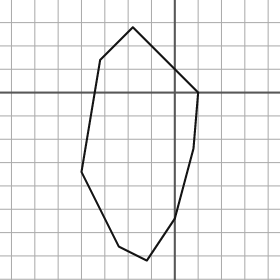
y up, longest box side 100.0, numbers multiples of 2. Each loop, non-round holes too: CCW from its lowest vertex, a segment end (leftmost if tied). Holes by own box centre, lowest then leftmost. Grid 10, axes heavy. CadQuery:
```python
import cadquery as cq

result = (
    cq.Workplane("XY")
    .moveTo(-12.0, -72.0)
    .lineTo(0.0, -54.0)
    .lineTo(8.0, -24.0)
    .lineTo(10.0, 0.0)
    .lineTo(-18.0, 28.0)
    .lineTo(-32.0, 14.0)
    .lineTo(-40.0, -34.0)
    .lineTo(-24.0, -66.0)
    .close()
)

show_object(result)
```